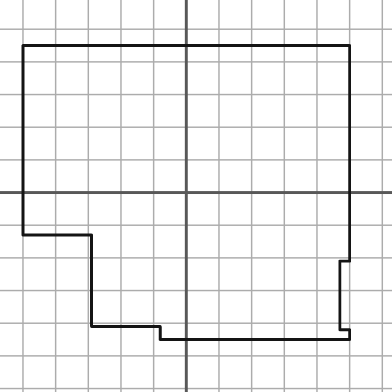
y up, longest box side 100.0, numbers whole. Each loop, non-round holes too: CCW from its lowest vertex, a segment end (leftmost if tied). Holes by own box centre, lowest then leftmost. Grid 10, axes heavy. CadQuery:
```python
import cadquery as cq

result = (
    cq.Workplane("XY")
    .moveTo(-8.0, -45.0)
    .lineTo(50.0, -45.0)
    .lineTo(50.0, -42.0)
    .lineTo(47.0, -42.0)
    .lineTo(47.0, -21.0)
    .lineTo(50.0, -21.0)
    .lineTo(50.0, 45.0)
    .lineTo(-50.0, 45.0)
    .lineTo(-50.0, -13.0)
    .lineTo(-29.0, -13.0)
    .lineTo(-29.0, -41.0)
    .lineTo(-8.0, -41.0)
    .close()
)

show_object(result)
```